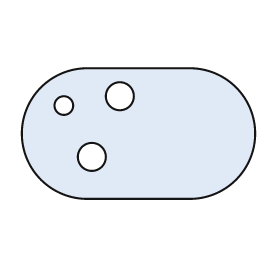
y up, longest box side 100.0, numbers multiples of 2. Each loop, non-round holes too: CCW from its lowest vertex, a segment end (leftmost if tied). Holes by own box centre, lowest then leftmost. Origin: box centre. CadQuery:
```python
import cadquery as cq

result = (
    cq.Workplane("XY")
    .moveTo(-22.0, -28.0)
    .lineTo(22.0, -28.0)
    .threePointArc((50.0, 0.0), (22.0, 28.0))
    .lineTo(-22.0, 28.0)
    .threePointArc((-50.0, 0.0), (-22.0, -28.0))
    .close()
    .moveTo(-20.0, -10.0)
    .circle(6.0)
    .moveTo(-32.0, 12.0)
    .circle(4.0)
    .moveTo(-8.0, 16.0)
    .circle(6.0)
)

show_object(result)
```